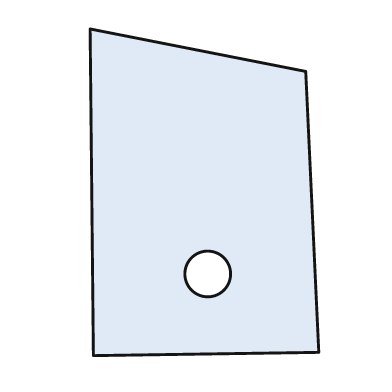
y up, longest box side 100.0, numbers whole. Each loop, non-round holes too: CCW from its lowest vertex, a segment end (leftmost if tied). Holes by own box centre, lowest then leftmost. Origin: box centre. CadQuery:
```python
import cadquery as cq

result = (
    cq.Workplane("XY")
    .moveTo(-34.0, -50.0)
    .lineTo(35.0, -49.0)
    .lineTo(31.0, 37.0)
    .lineTo(-35.0, 50.0)
    .close()
    .moveTo(1.0, -25.0)
    .circle(7.0)
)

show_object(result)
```